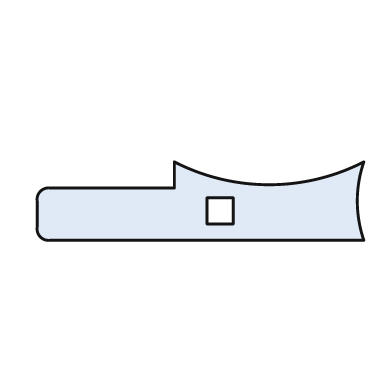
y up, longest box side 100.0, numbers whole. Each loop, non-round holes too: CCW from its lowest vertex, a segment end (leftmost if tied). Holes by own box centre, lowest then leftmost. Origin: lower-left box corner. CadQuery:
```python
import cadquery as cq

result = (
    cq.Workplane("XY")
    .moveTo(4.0, 0.0)
    .lineTo(100.0, 0.0)
    .threePointArc((98.0, 12.0), (100.0, 24.0))
    .threePointArc((71.0, 17.0), (42.0, 24.0))
    .lineTo(42.0, 16.0)
    .lineTo(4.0, 16.0)
    .threePointArc((1.0, 15.0), (0.0, 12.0))
    .lineTo(0.0, 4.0)
    .threePointArc((1.0, 1.0), (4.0, 0.0))
    .close()
    .moveTo(52.0, 5.0)
    .lineTo(60.0, 5.0)
    .lineTo(60.0, 13.0)
    .lineTo(52.0, 13.0)
    .close()
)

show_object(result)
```